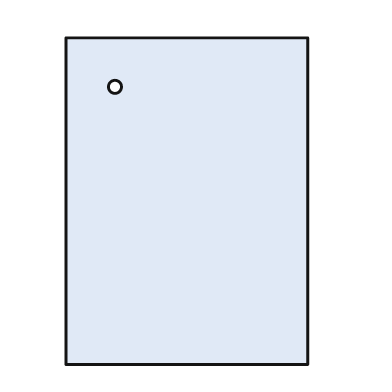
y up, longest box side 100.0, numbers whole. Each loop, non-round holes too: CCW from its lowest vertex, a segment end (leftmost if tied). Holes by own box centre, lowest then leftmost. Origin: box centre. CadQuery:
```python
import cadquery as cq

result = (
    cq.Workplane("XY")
    .moveTo(-37.0, -50.0)
    .lineTo(37.0, -50.0)
    .lineTo(37.0, 50.0)
    .lineTo(-37.0, 50.0)
    .close()
    .moveTo(-22.0, 35.0)
    .circle(2.0)
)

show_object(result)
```